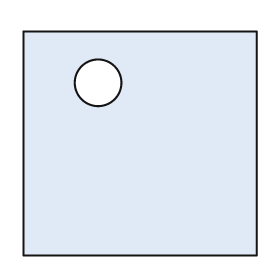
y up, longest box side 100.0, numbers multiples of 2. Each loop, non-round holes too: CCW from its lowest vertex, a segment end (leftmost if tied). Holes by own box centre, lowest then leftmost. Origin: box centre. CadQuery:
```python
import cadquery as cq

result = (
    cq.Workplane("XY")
    .moveTo(-50.0, -48.0)
    .lineTo(50.0, -48.0)
    .lineTo(50.0, 48.0)
    .lineTo(-50.0, 48.0)
    .close()
    .moveTo(-18.0, 26.0)
    .circle(10.0)
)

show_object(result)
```